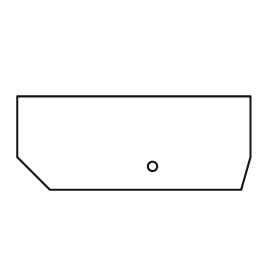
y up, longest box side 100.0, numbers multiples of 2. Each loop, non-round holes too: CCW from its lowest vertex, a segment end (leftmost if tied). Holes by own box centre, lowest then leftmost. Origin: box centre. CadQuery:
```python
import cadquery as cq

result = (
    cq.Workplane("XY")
    .moveTo(-36.0, -20.0)
    .lineTo(46.0, -20.0)
    .lineTo(50.0, -6.0)
    .lineTo(50.0, 20.0)
    .lineTo(-50.0, 20.0)
    .lineTo(-50.0, -6.0)
    .close()
    .moveTo(8.0, -10.0)
    .circle(2.0)
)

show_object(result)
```